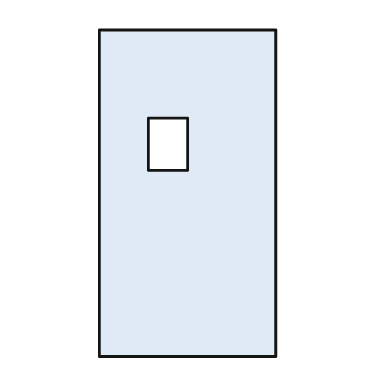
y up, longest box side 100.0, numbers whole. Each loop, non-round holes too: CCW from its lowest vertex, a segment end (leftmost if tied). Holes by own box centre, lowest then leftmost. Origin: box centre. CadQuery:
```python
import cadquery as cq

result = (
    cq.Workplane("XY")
    .moveTo(-27.0, -50.0)
    .lineTo(27.0, -50.0)
    .lineTo(27.0, 50.0)
    .lineTo(-27.0, 50.0)
    .close()
    .moveTo(-12.0, 7.0)
    .lineTo(0.0, 7.0)
    .lineTo(0.0, 23.0)
    .lineTo(-12.0, 23.0)
    .close()
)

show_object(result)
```